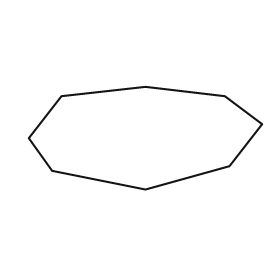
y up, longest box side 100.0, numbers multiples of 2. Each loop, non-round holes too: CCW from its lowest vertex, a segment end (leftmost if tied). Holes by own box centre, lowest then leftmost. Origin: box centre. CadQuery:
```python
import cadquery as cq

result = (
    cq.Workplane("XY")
    .moveTo(0.0, -22.0)
    .lineTo(36.0, -12.0)
    .lineTo(50.0, 6.0)
    .lineTo(34.0, 18.0)
    .lineTo(0.0, 22.0)
    .lineTo(-36.0, 18.0)
    .lineTo(-50.0, 0.0)
    .lineTo(-40.0, -14.0)
    .close()
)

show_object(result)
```